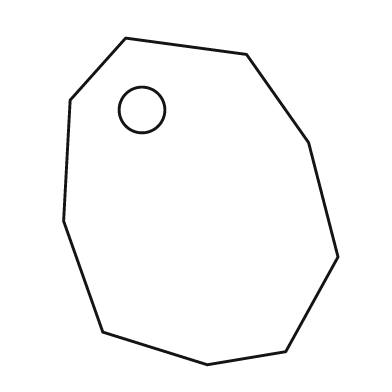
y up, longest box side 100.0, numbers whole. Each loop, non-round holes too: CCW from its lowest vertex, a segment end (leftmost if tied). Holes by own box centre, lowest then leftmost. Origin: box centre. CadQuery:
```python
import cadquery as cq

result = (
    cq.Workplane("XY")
    .moveTo(2.0, -50.0)
    .lineTo(26.0, -46.0)
    .lineTo(42.0, -17.0)
    .lineTo(33.0, 18.0)
    .lineTo(14.0, 45.0)
    .lineTo(-23.0, 50.0)
    .lineTo(-40.0, 31.0)
    .lineTo(-42.0, -6.0)
    .lineTo(-30.0, -40.0)
    .close()
    .moveTo(-18.0, 28.0)
    .circle(7.0)
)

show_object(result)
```